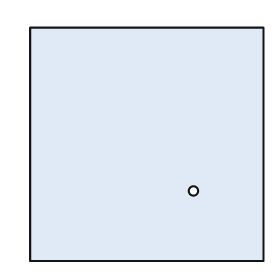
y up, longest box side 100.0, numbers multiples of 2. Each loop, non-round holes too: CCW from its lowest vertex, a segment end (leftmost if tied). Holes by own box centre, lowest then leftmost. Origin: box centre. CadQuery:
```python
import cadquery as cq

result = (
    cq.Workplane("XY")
    .moveTo(-50.0, -50.0)
    .lineTo(50.0, -50.0)
    .lineTo(50.0, 50.0)
    .lineTo(-50.0, 50.0)
    .close()
    .moveTo(20.0, -20.0)
    .circle(2.0)
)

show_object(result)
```